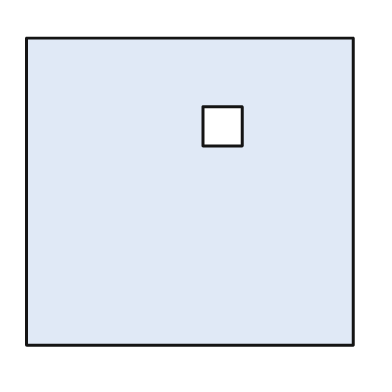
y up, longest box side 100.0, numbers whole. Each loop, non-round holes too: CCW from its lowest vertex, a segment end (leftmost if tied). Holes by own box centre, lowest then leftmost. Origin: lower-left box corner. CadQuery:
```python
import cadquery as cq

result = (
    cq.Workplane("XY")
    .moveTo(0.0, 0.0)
    .lineTo(100.0, 0.0)
    .lineTo(100.0, 94.0)
    .lineTo(0.0, 94.0)
    .close()
    .moveTo(54.0, 61.0)
    .lineTo(66.0, 61.0)
    .lineTo(66.0, 73.0)
    .lineTo(54.0, 73.0)
    .close()
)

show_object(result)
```